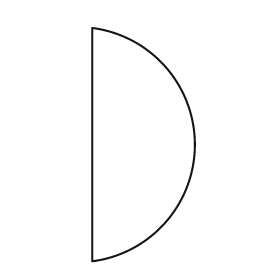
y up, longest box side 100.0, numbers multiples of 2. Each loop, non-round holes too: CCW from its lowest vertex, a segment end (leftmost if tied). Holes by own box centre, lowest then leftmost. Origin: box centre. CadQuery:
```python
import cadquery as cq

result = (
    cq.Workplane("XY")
    .moveTo(-22.0, -50.0)
    .threePointArc((22.0, 0.0), (-22.0, 50.0))
    .close()
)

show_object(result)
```